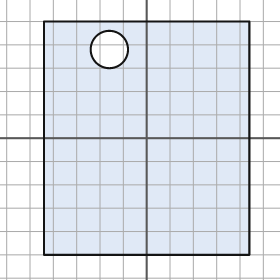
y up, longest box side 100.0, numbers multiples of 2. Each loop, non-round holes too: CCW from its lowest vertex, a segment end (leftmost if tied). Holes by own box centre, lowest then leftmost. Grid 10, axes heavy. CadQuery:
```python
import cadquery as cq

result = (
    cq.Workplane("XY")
    .moveTo(-44.0, -50.0)
    .lineTo(44.0, -50.0)
    .lineTo(44.0, 50.0)
    .lineTo(-44.0, 50.0)
    .close()
    .moveTo(-16.0, 38.0)
    .circle(8.0)
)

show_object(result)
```